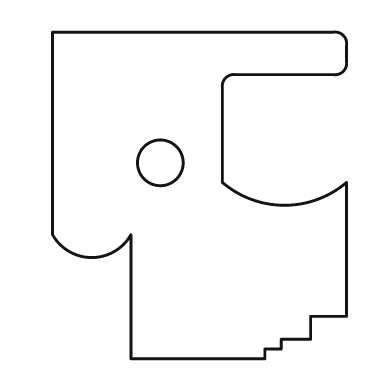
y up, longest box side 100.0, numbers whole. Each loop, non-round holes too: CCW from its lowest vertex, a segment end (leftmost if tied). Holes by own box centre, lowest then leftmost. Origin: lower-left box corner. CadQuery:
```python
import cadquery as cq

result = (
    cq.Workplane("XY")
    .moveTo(24.0, 0.0)
    .lineTo(65.0, 0.0)
    .lineTo(65.0, 3.0)
    .lineTo(70.0, 3.0)
    .lineTo(70.0, 6.0)
    .lineTo(79.0, 6.0)
    .lineTo(79.0, 13.0)
    .lineTo(90.0, 13.0)
    .lineTo(90.0, 54.0)
    .threePointArc((71.0, 47.0), (52.0, 54.0))
    .lineTo(52.0, 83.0)
    .threePointArc((53.0, 86.0), (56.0, 87.0))
    .lineTo(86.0, 87.0)
    .threePointArc((89.0, 88.0), (90.0, 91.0))
    .lineTo(90.0, 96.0)
    .threePointArc((89.0, 99.0), (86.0, 100.0))
    .lineTo(0.0, 100.0)
    .lineTo(0.0, 38.0)
    .threePointArc((12.0, 31.0), (24.0, 38.0))
    .close()
    .moveTo(33.0, 60.0)
    .circle(7.0)
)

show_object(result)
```